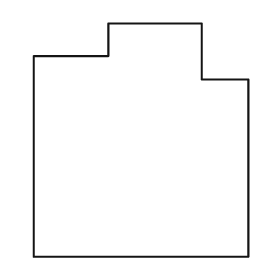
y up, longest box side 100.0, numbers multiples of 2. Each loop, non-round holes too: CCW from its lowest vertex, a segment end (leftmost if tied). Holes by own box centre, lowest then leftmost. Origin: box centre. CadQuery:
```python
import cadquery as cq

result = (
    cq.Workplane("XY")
    .moveTo(-46.0, -50.0)
    .lineTo(46.0, -50.0)
    .lineTo(46.0, 26.0)
    .lineTo(26.0, 26.0)
    .lineTo(26.0, 50.0)
    .lineTo(-14.0, 50.0)
    .lineTo(-14.0, 36.0)
    .lineTo(-46.0, 36.0)
    .close()
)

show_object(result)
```